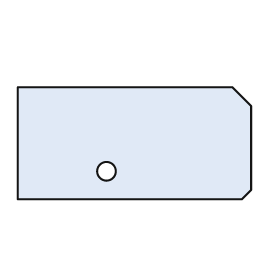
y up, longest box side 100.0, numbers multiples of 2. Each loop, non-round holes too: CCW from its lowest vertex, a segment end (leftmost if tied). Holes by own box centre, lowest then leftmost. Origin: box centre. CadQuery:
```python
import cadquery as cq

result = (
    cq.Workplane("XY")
    .moveTo(-50.0, -24.0)
    .lineTo(46.0, -24.0)
    .lineTo(50.0, -20.0)
    .lineTo(50.0, 16.0)
    .lineTo(42.0, 24.0)
    .lineTo(-50.0, 24.0)
    .close()
    .moveTo(-12.0, -12.0)
    .circle(4.0)
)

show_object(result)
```